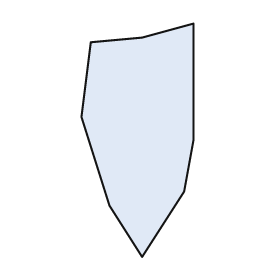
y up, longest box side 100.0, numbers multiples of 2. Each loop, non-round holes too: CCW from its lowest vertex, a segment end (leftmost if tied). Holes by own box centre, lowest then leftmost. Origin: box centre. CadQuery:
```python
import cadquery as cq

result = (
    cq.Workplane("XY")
    .moveTo(2.0, -50.0)
    .lineTo(20.0, -22.0)
    .lineTo(24.0, 0.0)
    .lineTo(24.0, 50.0)
    .lineTo(2.0, 44.0)
    .lineTo(-20.0, 42.0)
    .lineTo(-24.0, 10.0)
    .lineTo(-12.0, -28.0)
    .close()
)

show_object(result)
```